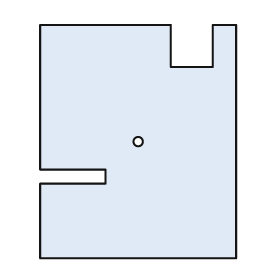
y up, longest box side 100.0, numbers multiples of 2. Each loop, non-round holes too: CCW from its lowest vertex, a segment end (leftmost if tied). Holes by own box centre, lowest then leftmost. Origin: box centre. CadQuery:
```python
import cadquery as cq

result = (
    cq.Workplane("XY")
    .moveTo(-42.0, -50.0)
    .lineTo(42.0, -50.0)
    .lineTo(42.0, 50.0)
    .lineTo(32.0, 50.0)
    .lineTo(32.0, 32.0)
    .lineTo(14.0, 32.0)
    .lineTo(14.0, 50.0)
    .lineTo(-42.0, 50.0)
    .lineTo(-42.0, -12.0)
    .lineTo(-14.0, -12.0)
    .lineTo(-14.0, -18.0)
    .lineTo(-42.0, -18.0)
    .close()
    .moveTo(0.0, 0.0)
    .circle(2.0)
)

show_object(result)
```